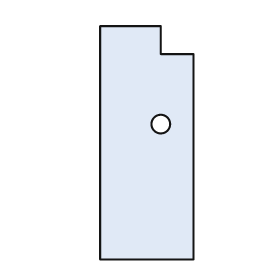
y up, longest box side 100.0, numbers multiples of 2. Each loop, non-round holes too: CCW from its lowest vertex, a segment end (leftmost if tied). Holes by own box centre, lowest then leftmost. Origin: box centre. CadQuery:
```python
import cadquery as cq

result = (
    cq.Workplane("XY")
    .moveTo(-20.0, -50.0)
    .lineTo(20.0, -50.0)
    .lineTo(20.0, 38.0)
    .lineTo(6.0, 38.0)
    .lineTo(6.0, 50.0)
    .lineTo(-20.0, 50.0)
    .close()
    .moveTo(6.0, 8.0)
    .circle(4.0)
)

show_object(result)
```